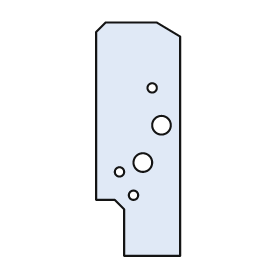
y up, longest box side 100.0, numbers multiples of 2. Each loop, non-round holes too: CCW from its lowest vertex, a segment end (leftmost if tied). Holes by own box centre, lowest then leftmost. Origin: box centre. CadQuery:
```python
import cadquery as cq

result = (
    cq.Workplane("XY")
    .moveTo(-6.0, -50.0)
    .lineTo(18.0, -50.0)
    .lineTo(18.0, 44.0)
    .lineTo(8.0, 50.0)
    .lineTo(-14.0, 50.0)
    .lineTo(-18.0, 46.0)
    .lineTo(-18.0, -26.0)
    .lineTo(-10.0, -26.0)
    .lineTo(-6.0, -30.0)
    .close()
    .moveTo(-2.0, -24.0)
    .circle(2.0)
    .moveTo(-8.0, -14.0)
    .circle(2.0)
    .moveTo(2.0, -10.0)
    .circle(4.0)
    .moveTo(10.0, 6.0)
    .circle(4.0)
    .moveTo(6.0, 22.0)
    .circle(2.0)
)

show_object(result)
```